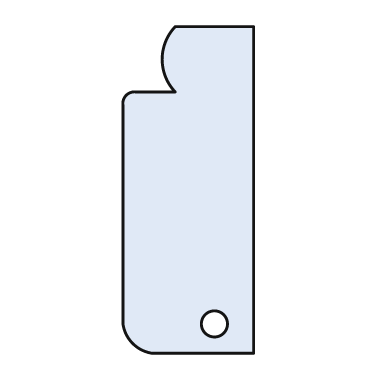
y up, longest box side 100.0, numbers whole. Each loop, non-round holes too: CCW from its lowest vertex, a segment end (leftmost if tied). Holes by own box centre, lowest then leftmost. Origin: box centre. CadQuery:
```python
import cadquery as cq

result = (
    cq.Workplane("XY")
    .moveTo(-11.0, -50.0)
    .lineTo(20.0, -50.0)
    .lineTo(20.0, 50.0)
    .lineTo(-4.0, 50.0)
    .threePointArc((-8.0, 40.0), (-4.0, 30.0))
    .lineTo(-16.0, 30.0)
    .threePointArc((-19.0, 29.0), (-20.0, 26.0))
    .lineTo(-20.0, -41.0)
    .threePointArc((-17.0, -47.0), (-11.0, -50.0))
    .close()
    .moveTo(8.0, -41.0)
    .circle(4.0)
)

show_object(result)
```